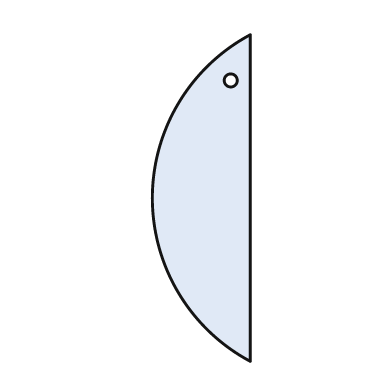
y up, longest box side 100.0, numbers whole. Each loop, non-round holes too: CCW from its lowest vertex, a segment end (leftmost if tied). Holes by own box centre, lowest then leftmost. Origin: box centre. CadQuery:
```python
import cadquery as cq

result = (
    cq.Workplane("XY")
    .moveTo(15.0, -50.0)
    .lineTo(15.0, 50.0)
    .threePointArc((-15.0, 0.0), (15.0, -50.0))
    .close()
    .moveTo(9.0, 36.0)
    .circle(2.0)
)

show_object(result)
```